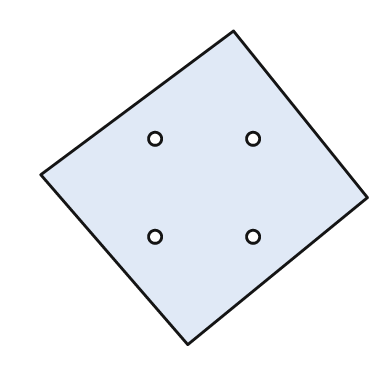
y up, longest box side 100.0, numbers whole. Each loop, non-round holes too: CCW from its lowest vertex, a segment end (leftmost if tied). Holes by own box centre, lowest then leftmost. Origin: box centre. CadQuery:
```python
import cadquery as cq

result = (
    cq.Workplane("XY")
    .moveTo(-5.0, -48.0)
    .lineTo(50.0, -3.0)
    .lineTo(9.0, 48.0)
    .lineTo(-50.0, 4.0)
    .close()
    .moveTo(-15.0, -15.0)
    .circle(2.0)
    .moveTo(15.0, -15.0)
    .circle(2.0)
    .moveTo(-15.0, 15.0)
    .circle(2.0)
    .moveTo(15.0, 15.0)
    .circle(2.0)
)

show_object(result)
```